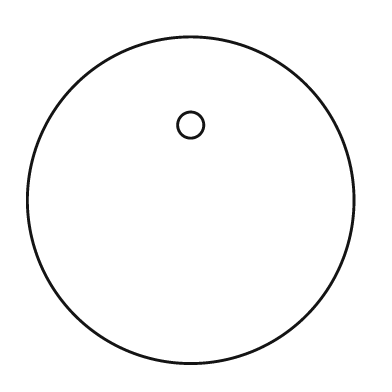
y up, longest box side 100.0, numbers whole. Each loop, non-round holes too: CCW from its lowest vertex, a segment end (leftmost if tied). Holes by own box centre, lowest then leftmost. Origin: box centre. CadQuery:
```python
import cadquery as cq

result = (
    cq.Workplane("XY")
    .moveTo(0.0, 0.0)
    .circle(50.0)
    .moveTo(0.0, 23.0)
    .circle(4.0)
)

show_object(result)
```